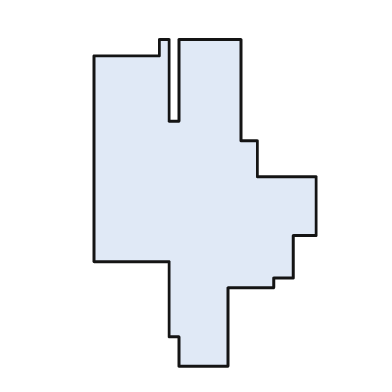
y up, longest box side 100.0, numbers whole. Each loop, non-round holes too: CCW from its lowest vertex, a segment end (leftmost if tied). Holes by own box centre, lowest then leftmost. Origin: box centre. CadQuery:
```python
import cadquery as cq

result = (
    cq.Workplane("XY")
    .moveTo(-8.0, -50.0)
    .lineTo(7.0, -50.0)
    .lineTo(7.0, -26.0)
    .lineTo(21.0, -26.0)
    .lineTo(21.0, -23.0)
    .lineTo(27.0, -23.0)
    .lineTo(27.0, -10.0)
    .lineTo(34.0, -10.0)
    .lineTo(34.0, 8.0)
    .lineTo(16.0, 8.0)
    .lineTo(16.0, 19.0)
    .lineTo(11.0, 19.0)
    .lineTo(11.0, 50.0)
    .lineTo(-8.0, 50.0)
    .lineTo(-8.0, 25.0)
    .lineTo(-11.0, 25.0)
    .lineTo(-11.0, 50.0)
    .lineTo(-14.0, 50.0)
    .lineTo(-14.0, 45.0)
    .lineTo(-34.0, 45.0)
    .lineTo(-34.0, -18.0)
    .lineTo(-11.0, -18.0)
    .lineTo(-11.0, -41.0)
    .lineTo(-8.0, -41.0)
    .close()
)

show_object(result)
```